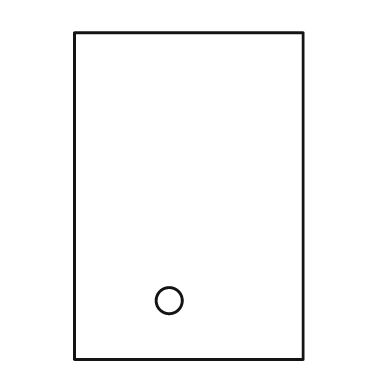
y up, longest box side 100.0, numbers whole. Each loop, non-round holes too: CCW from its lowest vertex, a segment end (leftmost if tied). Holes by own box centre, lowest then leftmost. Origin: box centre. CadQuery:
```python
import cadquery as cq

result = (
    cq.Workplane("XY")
    .moveTo(-35.0, -50.0)
    .lineTo(35.0, -50.0)
    .lineTo(35.0, 50.0)
    .lineTo(-35.0, 50.0)
    .close()
    .moveTo(-6.0, -32.0)
    .circle(4.0)
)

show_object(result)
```